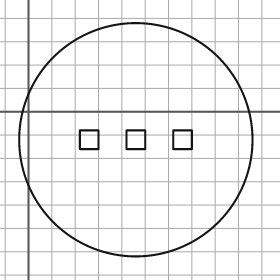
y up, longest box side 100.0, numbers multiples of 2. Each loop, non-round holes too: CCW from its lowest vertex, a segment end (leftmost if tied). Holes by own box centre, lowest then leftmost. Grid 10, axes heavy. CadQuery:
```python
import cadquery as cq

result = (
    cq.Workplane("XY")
    .moveTo(46.0, -12.0)
    .circle(50.0)
    .moveTo(22.0, -16.0)
    .lineTo(30.0, -16.0)
    .lineTo(30.0, -8.0)
    .lineTo(22.0, -8.0)
    .close()
    .moveTo(42.0, -16.0)
    .lineTo(50.0, -16.0)
    .lineTo(50.0, -8.0)
    .lineTo(42.0, -8.0)
    .close()
    .moveTo(62.0, -16.0)
    .lineTo(70.0, -16.0)
    .lineTo(70.0, -8.0)
    .lineTo(62.0, -8.0)
    .close()
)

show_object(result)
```